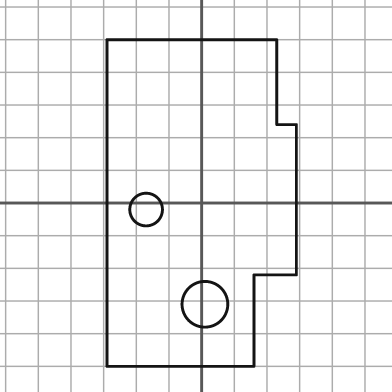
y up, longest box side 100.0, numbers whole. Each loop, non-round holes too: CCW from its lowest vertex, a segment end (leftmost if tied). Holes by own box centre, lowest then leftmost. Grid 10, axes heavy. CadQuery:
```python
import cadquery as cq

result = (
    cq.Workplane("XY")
    .moveTo(-29.0, -50.0)
    .lineTo(16.0, -50.0)
    .lineTo(16.0, -22.0)
    .lineTo(29.0, -22.0)
    .lineTo(29.0, 24.0)
    .lineTo(23.0, 24.0)
    .lineTo(23.0, 50.0)
    .lineTo(-29.0, 50.0)
    .close()
    .moveTo(1.0, -31.0)
    .circle(7.0)
    .moveTo(-17.0, -2.0)
    .circle(5.0)
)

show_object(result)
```